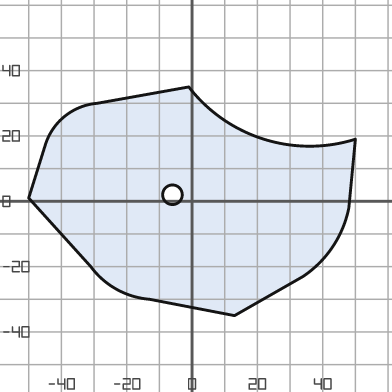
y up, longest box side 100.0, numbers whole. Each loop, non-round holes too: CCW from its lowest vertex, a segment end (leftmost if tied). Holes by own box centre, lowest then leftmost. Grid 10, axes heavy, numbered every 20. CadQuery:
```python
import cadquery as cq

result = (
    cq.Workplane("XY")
    .moveTo(13.0, -35.0)
    .lineTo(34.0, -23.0)
    .threePointArc((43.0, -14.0), (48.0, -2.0))
    .lineTo(50.0, 19.0)
    .threePointArc((22.0, 19.0), (-1.0, 35.0))
    .lineTo(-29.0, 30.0)
    .threePointArc((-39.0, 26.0), (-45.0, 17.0))
    .lineTo(-50.0, 1.0)
    .lineTo(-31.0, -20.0)
    .threePointArc((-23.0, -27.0), (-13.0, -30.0))
    .close()
    .moveTo(-6.0, 2.0)
    .circle(3.0)
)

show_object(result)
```